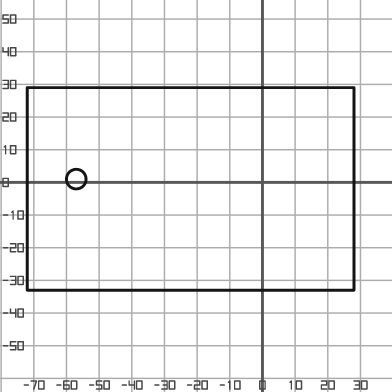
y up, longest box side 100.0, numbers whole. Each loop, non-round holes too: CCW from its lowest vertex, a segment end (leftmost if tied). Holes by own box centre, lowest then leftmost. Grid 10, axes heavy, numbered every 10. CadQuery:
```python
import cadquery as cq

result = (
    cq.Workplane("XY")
    .moveTo(-72.0, -33.0)
    .lineTo(28.0, -33.0)
    .lineTo(28.0, 29.0)
    .lineTo(-72.0, 29.0)
    .close()
    .moveTo(-57.0, 1.0)
    .circle(3.0)
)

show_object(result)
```